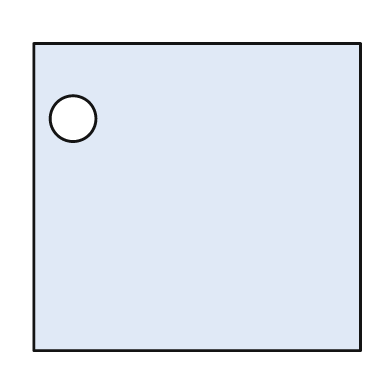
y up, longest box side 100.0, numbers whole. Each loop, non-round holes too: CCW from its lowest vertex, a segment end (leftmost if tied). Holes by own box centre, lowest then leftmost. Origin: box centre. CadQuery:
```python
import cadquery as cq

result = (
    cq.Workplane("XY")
    .moveTo(-50.0, -47.0)
    .lineTo(50.0, -47.0)
    .lineTo(50.0, 47.0)
    .lineTo(-50.0, 47.0)
    .close()
    .moveTo(-38.0, 24.0)
    .circle(7.0)
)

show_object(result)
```